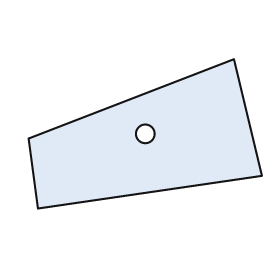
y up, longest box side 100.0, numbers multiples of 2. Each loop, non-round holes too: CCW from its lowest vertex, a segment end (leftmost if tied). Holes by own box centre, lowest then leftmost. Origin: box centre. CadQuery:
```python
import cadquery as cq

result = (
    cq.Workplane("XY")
    .moveTo(-46.0, -32.0)
    .lineTo(50.0, -18.0)
    .lineTo(38.0, 32.0)
    .lineTo(-50.0, -2.0)
    .close()
    .moveTo(0.0, 0.0)
    .circle(4.0)
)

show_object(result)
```